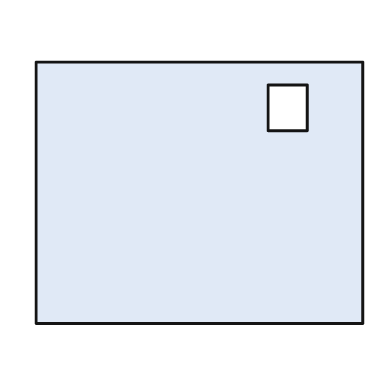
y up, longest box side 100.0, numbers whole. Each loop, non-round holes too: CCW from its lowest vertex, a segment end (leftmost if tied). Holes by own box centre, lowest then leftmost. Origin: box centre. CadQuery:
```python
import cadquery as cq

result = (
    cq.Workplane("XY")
    .moveTo(-50.0, -40.0)
    .lineTo(50.0, -40.0)
    .lineTo(50.0, 40.0)
    .lineTo(-50.0, 40.0)
    .close()
    .moveTo(21.0, 19.0)
    .lineTo(33.0, 19.0)
    .lineTo(33.0, 33.0)
    .lineTo(21.0, 33.0)
    .close()
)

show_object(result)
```